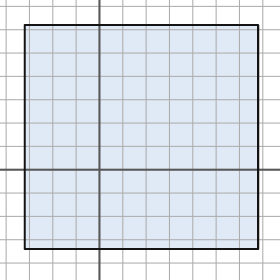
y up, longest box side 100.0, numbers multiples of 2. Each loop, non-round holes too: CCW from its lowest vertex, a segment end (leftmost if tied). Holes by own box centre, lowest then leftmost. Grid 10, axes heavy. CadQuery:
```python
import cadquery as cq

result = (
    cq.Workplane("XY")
    .moveTo(-32.0, -34.0)
    .lineTo(68.0, -34.0)
    .lineTo(68.0, 62.0)
    .lineTo(-32.0, 62.0)
    .close()
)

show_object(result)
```